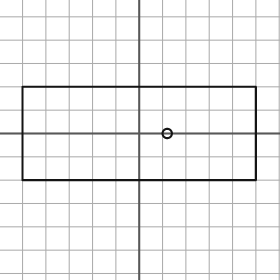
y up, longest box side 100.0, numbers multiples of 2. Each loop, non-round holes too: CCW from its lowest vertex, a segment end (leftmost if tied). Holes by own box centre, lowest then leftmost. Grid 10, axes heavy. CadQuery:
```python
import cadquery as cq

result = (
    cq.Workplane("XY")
    .moveTo(-50.0, -20.0)
    .lineTo(50.0, -20.0)
    .lineTo(50.0, 20.0)
    .lineTo(-50.0, 20.0)
    .close()
    .moveTo(12.0, 0.0)
    .circle(2.0)
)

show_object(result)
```